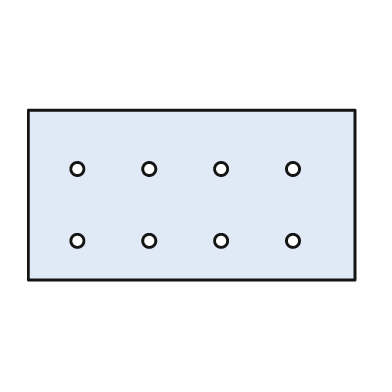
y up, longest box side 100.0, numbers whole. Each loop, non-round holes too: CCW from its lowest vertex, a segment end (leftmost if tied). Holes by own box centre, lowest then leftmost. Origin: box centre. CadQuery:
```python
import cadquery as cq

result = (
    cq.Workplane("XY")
    .moveTo(-50.0, -26.0)
    .lineTo(50.0, -26.0)
    .lineTo(50.0, 26.0)
    .lineTo(-50.0, 26.0)
    .close()
    .moveTo(-35.0, -14.0)
    .circle(2.0)
    .moveTo(-13.0, -14.0)
    .circle(2.0)
    .moveTo(9.0, -14.0)
    .circle(2.0)
    .moveTo(31.0, -14.0)
    .circle(2.0)
    .moveTo(-35.0, 8.0)
    .circle(2.0)
    .moveTo(-13.0, 8.0)
    .circle(2.0)
    .moveTo(9.0, 8.0)
    .circle(2.0)
    .moveTo(31.0, 8.0)
    .circle(2.0)
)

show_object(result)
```